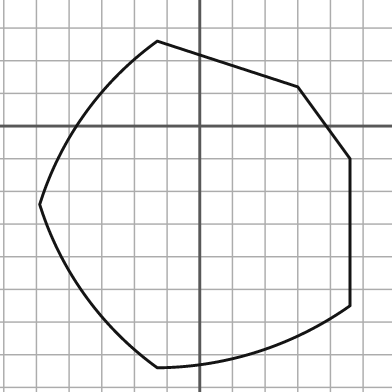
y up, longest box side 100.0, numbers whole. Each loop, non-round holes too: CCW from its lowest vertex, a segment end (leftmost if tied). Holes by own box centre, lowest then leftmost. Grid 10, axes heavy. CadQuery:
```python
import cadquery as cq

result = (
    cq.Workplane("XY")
    .moveTo(-13.0, -74.0)
    .threePointArc((18.0, -69.0), (46.0, -55.0))
    .lineTo(46.0, -10.0)
    .lineTo(30.0, 12.0)
    .lineTo(-13.0, 26.0)
    .threePointArc((-35.0, 4.0), (-49.0, -24.0))
    .threePointArc((-35.0, -52.0), (-13.0, -74.0))
    .close()
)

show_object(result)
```